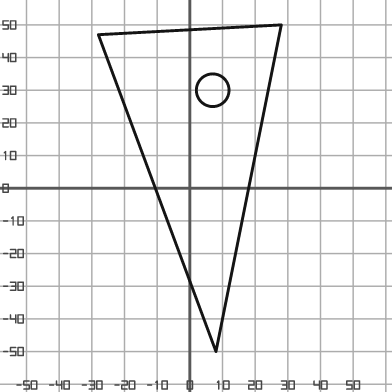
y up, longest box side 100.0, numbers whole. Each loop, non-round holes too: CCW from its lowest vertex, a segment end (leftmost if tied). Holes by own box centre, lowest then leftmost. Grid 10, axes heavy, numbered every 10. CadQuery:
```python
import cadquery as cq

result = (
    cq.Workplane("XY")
    .moveTo(8.0, -50.0)
    .lineTo(28.0, 50.0)
    .lineTo(-28.0, 47.0)
    .close()
    .moveTo(7.0, 30.0)
    .circle(5.0)
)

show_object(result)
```